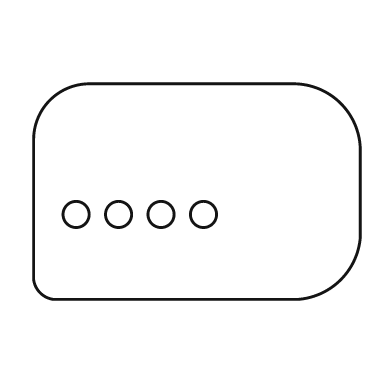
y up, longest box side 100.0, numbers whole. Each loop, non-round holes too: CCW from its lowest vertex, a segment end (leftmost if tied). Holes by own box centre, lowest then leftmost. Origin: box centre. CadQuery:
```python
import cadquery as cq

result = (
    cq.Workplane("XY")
    .moveTo(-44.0, -33.0)
    .lineTo(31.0, -33.0)
    .threePointArc((44.0, -27.0), (50.0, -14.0))
    .lineTo(50.0, 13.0)
    .threePointArc((44.0, 27.0), (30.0, 33.0))
    .lineTo(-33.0, 33.0)
    .threePointArc((-45.0, 28.0), (-50.0, 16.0))
    .lineTo(-50.0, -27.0)
    .threePointArc((-48.0, -31.0), (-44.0, -33.0))
    .close()
    .moveTo(-37.0, -7.0)
    .circle(4.0)
    .moveTo(-24.0, -7.0)
    .circle(4.0)
    .moveTo(-11.0, -7.0)
    .circle(4.0)
    .moveTo(2.0, -7.0)
    .circle(4.0)
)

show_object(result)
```